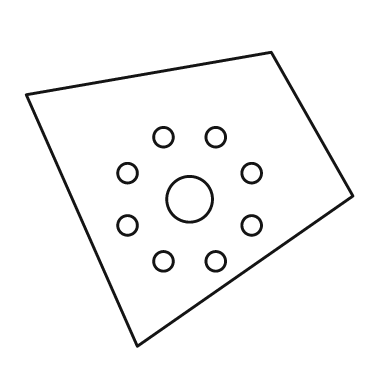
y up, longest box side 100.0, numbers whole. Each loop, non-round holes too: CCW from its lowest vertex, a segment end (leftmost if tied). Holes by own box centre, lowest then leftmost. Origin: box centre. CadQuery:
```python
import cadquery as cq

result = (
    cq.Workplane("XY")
    .moveTo(-16.0, -45.0)
    .lineTo(50.0, 1.0)
    .lineTo(25.0, 45.0)
    .lineTo(-50.0, 32.0)
    .close()
    .moveTo(-8.0, -19.0)
    .circle(3.0)
    .moveTo(8.0, -19.0)
    .circle(3.0)
    .moveTo(-19.0, -8.0)
    .circle(3.0)
    .moveTo(19.0, -8.0)
    .circle(3.0)
    .moveTo(0.0, 0.0)
    .circle(7.0)
    .moveTo(-19.0, 8.0)
    .circle(3.0)
    .moveTo(19.0, 8.0)
    .circle(3.0)
    .moveTo(-8.0, 19.0)
    .circle(3.0)
    .moveTo(8.0, 19.0)
    .circle(3.0)
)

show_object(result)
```